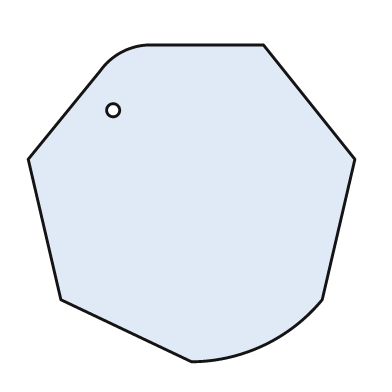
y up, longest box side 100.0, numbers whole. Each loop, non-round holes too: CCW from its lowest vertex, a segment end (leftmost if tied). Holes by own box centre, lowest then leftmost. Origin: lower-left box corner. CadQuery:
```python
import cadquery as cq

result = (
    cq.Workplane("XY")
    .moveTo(50.0, 0.0)
    .threePointArc((72.0, 5.0), (90.0, 19.0))
    .lineTo(100.0, 62.0)
    .lineTo(72.0, 97.0)
    .lineTo(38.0, 97.0)
    .threePointArc((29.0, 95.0), (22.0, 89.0))
    .lineTo(0.0, 62.0)
    .lineTo(10.0, 19.0)
    .close()
    .moveTo(26.0, 77.0)
    .circle(2.0)
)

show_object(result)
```